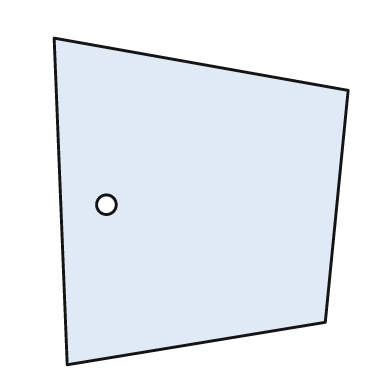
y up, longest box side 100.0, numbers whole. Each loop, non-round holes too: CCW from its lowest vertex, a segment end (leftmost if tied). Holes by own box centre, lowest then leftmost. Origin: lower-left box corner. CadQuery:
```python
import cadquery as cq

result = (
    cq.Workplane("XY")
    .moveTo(4.0, 0.0)
    .lineTo(83.0, 13.0)
    .lineTo(90.0, 84.0)
    .lineTo(0.0, 100.0)
    .close()
    .moveTo(16.0, 49.0)
    .circle(3.0)
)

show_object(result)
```